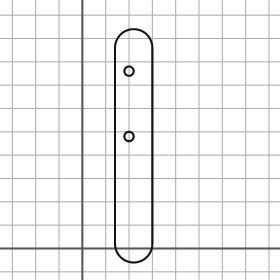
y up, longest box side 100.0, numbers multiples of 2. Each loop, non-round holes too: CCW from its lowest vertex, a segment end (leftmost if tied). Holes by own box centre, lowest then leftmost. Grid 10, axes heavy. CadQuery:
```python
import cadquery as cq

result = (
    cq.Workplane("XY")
    .moveTo(14.0, 2.0)
    .threePointArc((22.0, -6.0), (30.0, 2.0))
    .lineTo(30.0, 86.0)
    .threePointArc((22.0, 94.0), (14.0, 86.0))
    .close()
    .moveTo(20.0, 48.0)
    .circle(2.0)
    .moveTo(20.0, 76.0)
    .circle(2.0)
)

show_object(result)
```